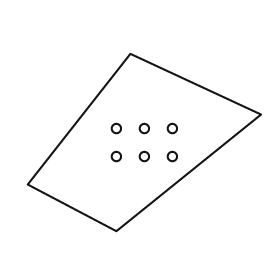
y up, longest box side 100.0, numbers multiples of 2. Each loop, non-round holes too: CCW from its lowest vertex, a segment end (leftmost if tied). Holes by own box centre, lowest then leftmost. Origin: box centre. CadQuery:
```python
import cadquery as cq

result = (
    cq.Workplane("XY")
    .moveTo(-12.0, -38.0)
    .lineTo(50.0, 12.0)
    .lineTo(-6.0, 38.0)
    .lineTo(-50.0, -18.0)
    .close()
    .moveTo(-12.0, -6.0)
    .circle(2.0)
    .moveTo(0.0, -6.0)
    .circle(2.0)
    .moveTo(12.0, -6.0)
    .circle(2.0)
    .moveTo(-12.0, 6.0)
    .circle(2.0)
    .moveTo(0.0, 6.0)
    .circle(2.0)
    .moveTo(12.0, 6.0)
    .circle(2.0)
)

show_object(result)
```